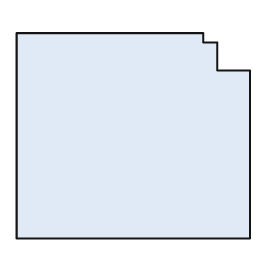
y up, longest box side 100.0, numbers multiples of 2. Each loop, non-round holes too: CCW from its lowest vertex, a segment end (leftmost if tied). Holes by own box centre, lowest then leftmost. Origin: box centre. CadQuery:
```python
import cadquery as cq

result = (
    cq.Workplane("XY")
    .moveTo(-50.0, -44.0)
    .lineTo(50.0, -44.0)
    .lineTo(50.0, 28.0)
    .lineTo(36.0, 28.0)
    .lineTo(36.0, 40.0)
    .lineTo(30.0, 40.0)
    .lineTo(30.0, 44.0)
    .lineTo(-50.0, 44.0)
    .close()
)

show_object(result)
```